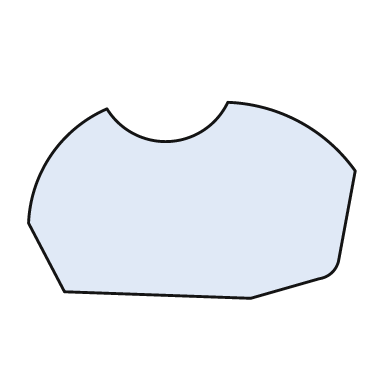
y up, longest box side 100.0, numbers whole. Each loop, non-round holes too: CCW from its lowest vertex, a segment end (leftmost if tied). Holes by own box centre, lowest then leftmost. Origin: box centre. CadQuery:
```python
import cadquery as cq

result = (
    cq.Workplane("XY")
    .moveTo(18.0, -30.0)
    .lineTo(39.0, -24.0)
    .threePointArc((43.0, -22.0), (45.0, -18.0))
    .lineTo(50.0, 9.0)
    .threePointArc((33.0, 24.0), (11.0, 30.0))
    .threePointArc((-7.0, 18.0), (-26.0, 28.0))
    .threePointArc((-43.0, 14.0), (-50.0, -7.0))
    .lineTo(-39.0, -28.0)
    .close()
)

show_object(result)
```